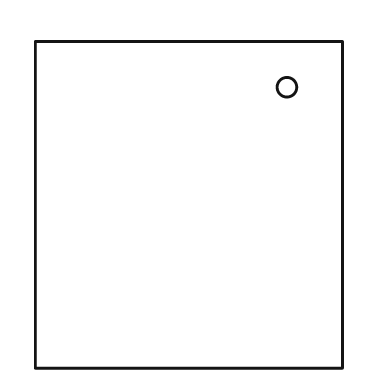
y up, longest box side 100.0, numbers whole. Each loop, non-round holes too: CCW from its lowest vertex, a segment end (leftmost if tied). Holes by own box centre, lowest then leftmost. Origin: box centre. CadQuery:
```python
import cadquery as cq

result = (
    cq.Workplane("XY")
    .moveTo(-47.0, -50.0)
    .lineTo(47.0, -50.0)
    .lineTo(47.0, 50.0)
    .lineTo(-47.0, 50.0)
    .close()
    .moveTo(30.0, 36.0)
    .circle(3.0)
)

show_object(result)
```